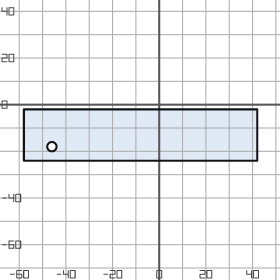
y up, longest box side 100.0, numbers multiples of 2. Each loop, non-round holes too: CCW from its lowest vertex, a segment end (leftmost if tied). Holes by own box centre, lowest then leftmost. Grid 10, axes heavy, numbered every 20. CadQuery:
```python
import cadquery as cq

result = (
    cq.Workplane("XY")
    .moveTo(-58.0, -24.0)
    .lineTo(42.0, -24.0)
    .lineTo(42.0, -2.0)
    .lineTo(-58.0, -2.0)
    .close()
    .moveTo(-46.0, -18.0)
    .circle(2.0)
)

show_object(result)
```